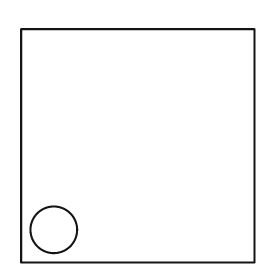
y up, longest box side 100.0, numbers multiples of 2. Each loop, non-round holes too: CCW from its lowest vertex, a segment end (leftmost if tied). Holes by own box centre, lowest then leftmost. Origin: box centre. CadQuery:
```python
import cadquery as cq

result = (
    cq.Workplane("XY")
    .moveTo(-50.0, -50.0)
    .lineTo(50.0, -50.0)
    .lineTo(50.0, 50.0)
    .lineTo(-50.0, 50.0)
    .close()
    .moveTo(-36.0, -36.0)
    .circle(10.0)
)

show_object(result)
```